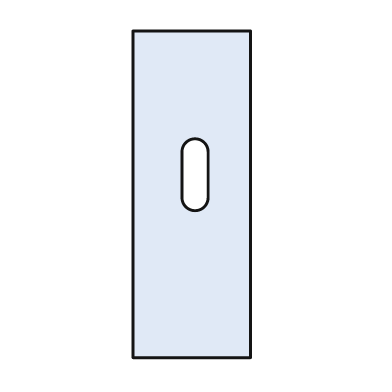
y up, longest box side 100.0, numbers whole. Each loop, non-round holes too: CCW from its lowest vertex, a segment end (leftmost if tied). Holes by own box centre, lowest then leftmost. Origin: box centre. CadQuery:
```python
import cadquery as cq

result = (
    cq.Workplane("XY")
    .moveTo(-18.0, -50.0)
    .lineTo(18.0, -50.0)
    .lineTo(18.0, 50.0)
    .lineTo(-18.0, 50.0)
    .close()
    .moveTo(-3.0, -1.0)
    .threePointArc((1.0, -5.0), (5.0, -1.0))
    .lineTo(5.0, 13.0)
    .threePointArc((1.0, 17.0), (-3.0, 13.0))
    .close()
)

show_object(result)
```